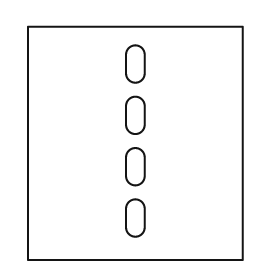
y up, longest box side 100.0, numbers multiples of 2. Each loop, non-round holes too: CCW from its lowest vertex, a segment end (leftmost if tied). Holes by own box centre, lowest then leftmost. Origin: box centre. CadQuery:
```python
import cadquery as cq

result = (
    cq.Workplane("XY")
    .moveTo(-46.0, -50.0)
    .lineTo(46.0, -50.0)
    .lineTo(46.0, 50.0)
    .lineTo(-46.0, 50.0)
    .close()
    .moveTo(-4.0, -36.0)
    .threePointArc((0.0, -40.0), (4.0, -36.0))
    .lineTo(4.0, -28.0)
    .threePointArc((0.0, -24.0), (-4.0, -28.0))
    .close()
    .moveTo(-4.0, -14.0)
    .threePointArc((0.0, -18.0), (4.0, -14.0))
    .lineTo(4.0, -6.0)
    .threePointArc((0.0, -2.0), (-4.0, -6.0))
    .close()
    .moveTo(-4.0, 8.0)
    .threePointArc((0.0, 4.0), (4.0, 8.0))
    .lineTo(4.0, 16.0)
    .threePointArc((0.0, 20.0), (-4.0, 16.0))
    .close()
    .moveTo(-4.0, 30.0)
    .threePointArc((0.0, 26.0), (4.0, 30.0))
    .lineTo(4.0, 38.0)
    .threePointArc((0.0, 42.0), (-4.0, 38.0))
    .close()
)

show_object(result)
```